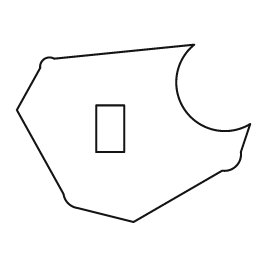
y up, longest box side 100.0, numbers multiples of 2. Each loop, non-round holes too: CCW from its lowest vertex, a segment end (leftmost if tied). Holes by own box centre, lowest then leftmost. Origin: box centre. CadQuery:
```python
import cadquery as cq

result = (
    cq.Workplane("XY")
    .moveTo(0.0, -38.0)
    .lineTo(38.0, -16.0)
    .threePointArc((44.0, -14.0), (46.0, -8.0))
    .lineTo(50.0, 4.0)
    .threePointArc((22.0, 10.0), (26.0, 38.0))
    .lineTo(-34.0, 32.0)
    .threePointArc((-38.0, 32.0), (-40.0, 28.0))
    .lineTo(-50.0, 10.0)
    .lineTo(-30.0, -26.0)
    .threePointArc((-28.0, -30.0), (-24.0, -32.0))
    .close()
    .moveTo(-16.0, -8.0)
    .lineTo(-4.0, -8.0)
    .lineTo(-4.0, 12.0)
    .lineTo(-16.0, 12.0)
    .close()
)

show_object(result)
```